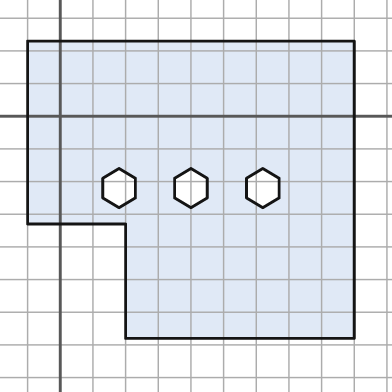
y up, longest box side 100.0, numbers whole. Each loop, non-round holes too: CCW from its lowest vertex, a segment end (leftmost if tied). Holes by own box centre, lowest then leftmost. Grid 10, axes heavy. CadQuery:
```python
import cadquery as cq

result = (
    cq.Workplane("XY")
    .moveTo(20.0, -68.0)
    .lineTo(90.0, -68.0)
    .lineTo(90.0, 23.0)
    .lineTo(-10.0, 23.0)
    .lineTo(-10.0, -33.0)
    .lineTo(20.0, -33.0)
    .close()
    .moveTo(18.0, -28.0)
    .lineTo(23.0, -25.0)
    .lineTo(23.0, -19.0)
    .lineTo(18.0, -16.0)
    .lineTo(13.0, -19.0)
    .lineTo(13.0, -25.0)
    .close()
    .moveTo(40.0, -28.0)
    .lineTo(45.0, -25.0)
    .lineTo(45.0, -19.0)
    .lineTo(40.0, -16.0)
    .lineTo(35.0, -19.0)
    .lineTo(35.0, -25.0)
    .close()
    .moveTo(62.0, -28.0)
    .lineTo(67.0, -25.0)
    .lineTo(67.0, -19.0)
    .lineTo(62.0, -16.0)
    .lineTo(57.0, -19.0)
    .lineTo(57.0, -25.0)
    .close()
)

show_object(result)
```